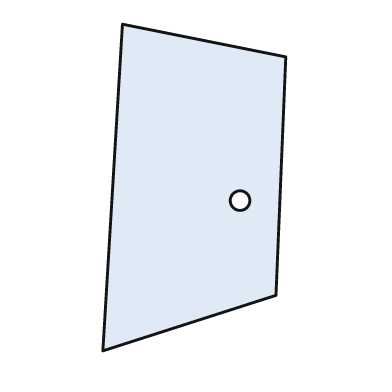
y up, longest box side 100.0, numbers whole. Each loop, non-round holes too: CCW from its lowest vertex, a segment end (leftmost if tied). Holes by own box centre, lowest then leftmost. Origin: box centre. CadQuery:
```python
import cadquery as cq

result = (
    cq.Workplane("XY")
    .moveTo(-28.0, -50.0)
    .lineTo(25.0, -33.0)
    .lineTo(28.0, 40.0)
    .lineTo(-22.0, 50.0)
    .close()
    .moveTo(14.0, -4.0)
    .circle(3.0)
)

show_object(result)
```